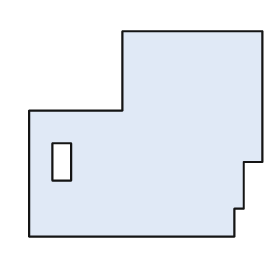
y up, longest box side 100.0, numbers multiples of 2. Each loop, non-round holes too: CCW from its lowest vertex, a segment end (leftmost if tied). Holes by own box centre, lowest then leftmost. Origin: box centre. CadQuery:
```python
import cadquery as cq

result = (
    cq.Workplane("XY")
    .moveTo(-50.0, -44.0)
    .lineTo(38.0, -44.0)
    .lineTo(38.0, -32.0)
    .lineTo(42.0, -32.0)
    .lineTo(42.0, -12.0)
    .lineTo(50.0, -12.0)
    .lineTo(50.0, 44.0)
    .lineTo(-10.0, 44.0)
    .lineTo(-10.0, 10.0)
    .lineTo(-50.0, 10.0)
    .close()
    .moveTo(-40.0, -20.0)
    .lineTo(-32.0, -20.0)
    .lineTo(-32.0, -4.0)
    .lineTo(-40.0, -4.0)
    .close()
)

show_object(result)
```